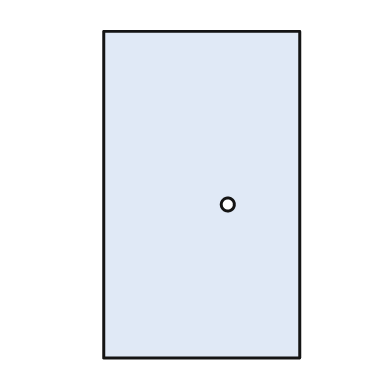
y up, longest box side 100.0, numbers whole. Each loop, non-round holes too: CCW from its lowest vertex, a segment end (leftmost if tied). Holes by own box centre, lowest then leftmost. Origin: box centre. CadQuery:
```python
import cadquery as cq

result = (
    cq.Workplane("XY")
    .moveTo(-30.0, -50.0)
    .lineTo(30.0, -50.0)
    .lineTo(30.0, 50.0)
    .lineTo(-30.0, 50.0)
    .close()
    .moveTo(8.0, -3.0)
    .circle(2.0)
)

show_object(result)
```